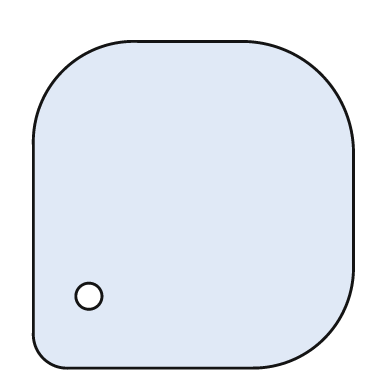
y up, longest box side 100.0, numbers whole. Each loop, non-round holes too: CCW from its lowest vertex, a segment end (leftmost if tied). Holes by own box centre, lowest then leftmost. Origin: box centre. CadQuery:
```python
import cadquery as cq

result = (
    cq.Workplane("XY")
    .moveTo(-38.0, -50.0)
    .lineTo(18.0, -50.0)
    .threePointArc((40.0, -41.0), (49.0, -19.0))
    .lineTo(49.0, 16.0)
    .threePointArc((39.0, 40.0), (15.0, 50.0))
    .lineTo(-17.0, 50.0)
    .threePointArc((-40.0, 41.0), (-49.0, 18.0))
    .lineTo(-49.0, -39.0)
    .threePointArc((-46.0, -47.0), (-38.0, -50.0))
    .close()
    .moveTo(-32.0, -28.0)
    .circle(4.0)
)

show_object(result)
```